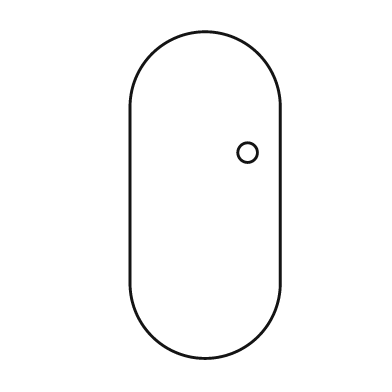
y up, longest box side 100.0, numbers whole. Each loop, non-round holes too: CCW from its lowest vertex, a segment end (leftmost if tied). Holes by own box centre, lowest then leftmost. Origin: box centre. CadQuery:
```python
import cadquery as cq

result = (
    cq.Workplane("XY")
    .moveTo(-23.0, -27.0)
    .threePointArc((0.0, -50.0), (23.0, -27.0))
    .lineTo(23.0, 27.0)
    .threePointArc((0.0, 50.0), (-23.0, 27.0))
    .close()
    .moveTo(13.0, 13.0)
    .circle(3.0)
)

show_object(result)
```